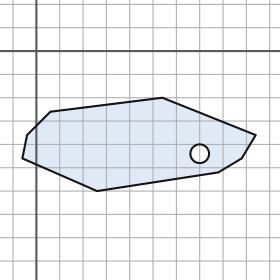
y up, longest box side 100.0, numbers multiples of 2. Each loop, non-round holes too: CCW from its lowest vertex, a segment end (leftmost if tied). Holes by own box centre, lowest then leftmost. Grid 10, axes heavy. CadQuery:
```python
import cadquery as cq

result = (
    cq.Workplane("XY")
    .moveTo(26.0, -60.0)
    .lineTo(78.0, -52.0)
    .lineTo(88.0, -46.0)
    .lineTo(94.0, -36.0)
    .lineTo(54.0, -20.0)
    .lineTo(6.0, -26.0)
    .lineTo(-4.0, -36.0)
    .lineTo(-6.0, -46.0)
    .close()
    .moveTo(70.0, -44.0)
    .circle(4.0)
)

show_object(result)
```